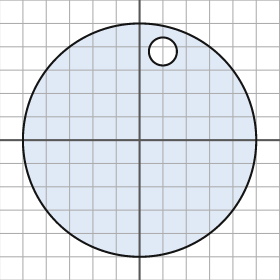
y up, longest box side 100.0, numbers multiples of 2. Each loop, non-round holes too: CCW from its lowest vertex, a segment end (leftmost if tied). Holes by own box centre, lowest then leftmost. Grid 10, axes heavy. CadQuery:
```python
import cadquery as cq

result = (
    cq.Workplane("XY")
    .moveTo(0.0, 0.0)
    .circle(50.0)
    .moveTo(10.0, 38.0)
    .circle(6.0)
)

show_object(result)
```